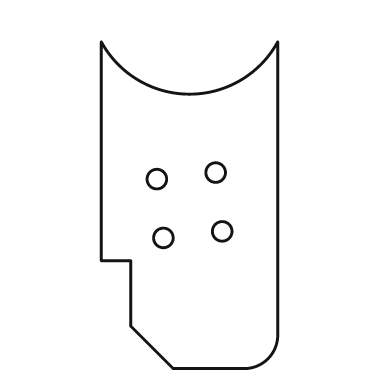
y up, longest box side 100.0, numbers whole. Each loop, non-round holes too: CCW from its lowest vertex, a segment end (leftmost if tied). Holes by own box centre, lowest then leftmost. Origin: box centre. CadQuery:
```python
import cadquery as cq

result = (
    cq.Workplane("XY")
    .moveTo(-5.0, -50.0)
    .lineTo(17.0, -50.0)
    .threePointArc((24.0, -47.0), (27.0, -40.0))
    .lineTo(27.0, 50.0)
    .threePointArc((0.0, 34.0), (-27.0, 50.0))
    .lineTo(-27.0, -17.0)
    .lineTo(-18.0, -17.0)
    .lineTo(-18.0, -37.0)
    .close()
    .moveTo(-8.0, -10.0)
    .circle(3.0)
    .moveTo(10.0, -8.0)
    .circle(3.0)
    .moveTo(-10.0, 8.0)
    .circle(3.0)
    .moveTo(8.0, 10.0)
    .circle(3.0)
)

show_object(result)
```